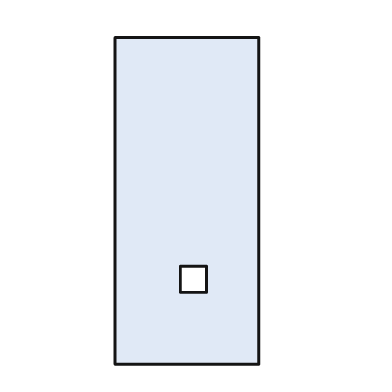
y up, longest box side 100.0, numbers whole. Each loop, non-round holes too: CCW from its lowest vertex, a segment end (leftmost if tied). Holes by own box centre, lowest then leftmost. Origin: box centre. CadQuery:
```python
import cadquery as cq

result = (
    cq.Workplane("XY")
    .moveTo(-22.0, -50.0)
    .lineTo(22.0, -50.0)
    .lineTo(22.0, 50.0)
    .lineTo(-22.0, 50.0)
    .close()
    .moveTo(-2.0, -28.0)
    .lineTo(6.0, -28.0)
    .lineTo(6.0, -20.0)
    .lineTo(-2.0, -20.0)
    .close()
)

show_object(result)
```